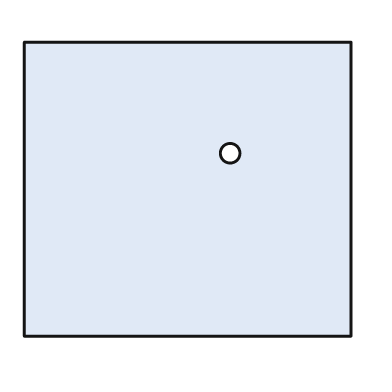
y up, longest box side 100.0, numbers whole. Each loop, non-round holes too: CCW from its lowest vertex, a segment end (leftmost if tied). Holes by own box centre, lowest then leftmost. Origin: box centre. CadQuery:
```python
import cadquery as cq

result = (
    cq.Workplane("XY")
    .moveTo(-50.0, -45.0)
    .lineTo(50.0, -45.0)
    .lineTo(50.0, 45.0)
    .lineTo(-50.0, 45.0)
    .close()
    .moveTo(13.0, 11.0)
    .circle(3.0)
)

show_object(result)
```